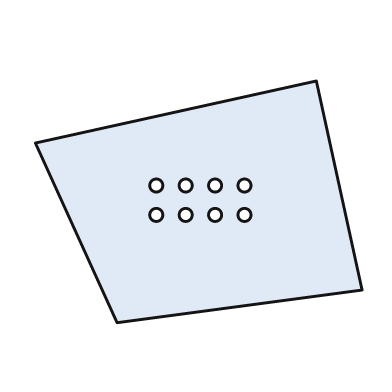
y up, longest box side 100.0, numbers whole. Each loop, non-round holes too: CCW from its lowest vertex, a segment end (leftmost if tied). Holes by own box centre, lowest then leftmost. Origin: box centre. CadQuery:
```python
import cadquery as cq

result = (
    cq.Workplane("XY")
    .moveTo(-25.0, -37.0)
    .lineTo(50.0, -27.0)
    .lineTo(36.0, 37.0)
    .lineTo(-50.0, 18.0)
    .close()
    .moveTo(-13.0, -4.0)
    .circle(2.0)
    .moveTo(-4.0, -4.0)
    .circle(2.0)
    .moveTo(5.0, -4.0)
    .circle(2.0)
    .moveTo(14.0, -4.0)
    .circle(2.0)
    .moveTo(-13.0, 5.0)
    .circle(2.0)
    .moveTo(-4.0, 5.0)
    .circle(2.0)
    .moveTo(5.0, 5.0)
    .circle(2.0)
    .moveTo(14.0, 5.0)
    .circle(2.0)
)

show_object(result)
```